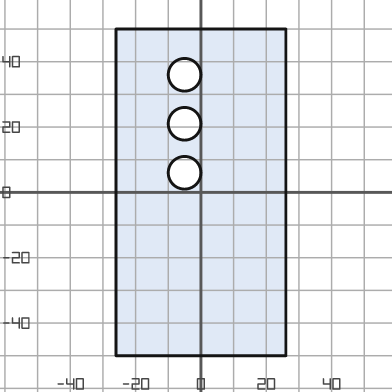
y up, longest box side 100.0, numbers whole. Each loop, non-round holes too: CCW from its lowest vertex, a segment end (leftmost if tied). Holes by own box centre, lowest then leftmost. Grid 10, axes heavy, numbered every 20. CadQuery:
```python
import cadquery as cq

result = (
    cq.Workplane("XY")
    .moveTo(-26.0, -50.0)
    .lineTo(26.0, -50.0)
    .lineTo(26.0, 50.0)
    .lineTo(-26.0, 50.0)
    .close()
    .moveTo(-5.0, 6.0)
    .circle(5.0)
    .moveTo(-5.0, 21.0)
    .circle(5.0)
    .moveTo(-5.0, 36.0)
    .circle(5.0)
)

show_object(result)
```